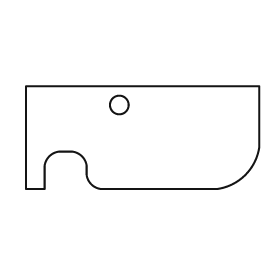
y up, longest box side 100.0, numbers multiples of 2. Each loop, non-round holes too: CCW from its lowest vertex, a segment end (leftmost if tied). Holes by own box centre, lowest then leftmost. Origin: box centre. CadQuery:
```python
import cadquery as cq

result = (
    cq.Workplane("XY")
    .moveTo(-50.0, -22.0)
    .lineTo(-42.0, -22.0)
    .lineTo(-42.0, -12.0)
    .threePointArc((-40.0, -8.0), (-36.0, -6.0))
    .lineTo(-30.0, -6.0)
    .threePointArc((-26.0, -8.0), (-24.0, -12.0))
    .lineTo(-24.0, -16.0)
    .threePointArc((-22.0, -20.0), (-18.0, -22.0))
    .lineTo(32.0, -22.0)
    .threePointArc((44.0, -16.0), (50.0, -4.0))
    .lineTo(50.0, 22.0)
    .lineTo(-50.0, 22.0)
    .close()
    .moveTo(-10.0, 14.0)
    .circle(4.0)
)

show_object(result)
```